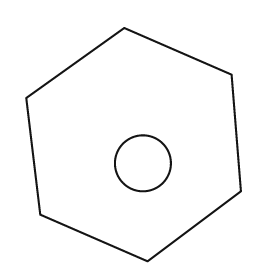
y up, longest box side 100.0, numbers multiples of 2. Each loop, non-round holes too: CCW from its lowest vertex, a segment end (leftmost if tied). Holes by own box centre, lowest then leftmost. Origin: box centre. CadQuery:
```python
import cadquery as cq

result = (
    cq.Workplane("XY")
    .moveTo(6.0, -50.0)
    .lineTo(46.0, -20.0)
    .lineTo(42.0, 30.0)
    .lineTo(-4.0, 50.0)
    .lineTo(-46.0, 20.0)
    .lineTo(-40.0, -30.0)
    .close()
    .moveTo(4.0, -8.0)
    .circle(12.0)
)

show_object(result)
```